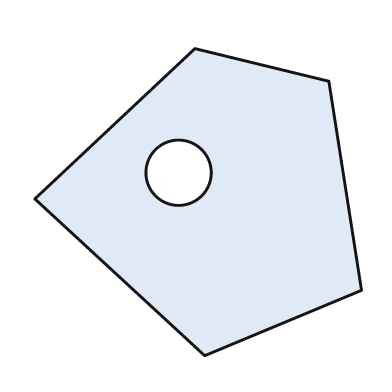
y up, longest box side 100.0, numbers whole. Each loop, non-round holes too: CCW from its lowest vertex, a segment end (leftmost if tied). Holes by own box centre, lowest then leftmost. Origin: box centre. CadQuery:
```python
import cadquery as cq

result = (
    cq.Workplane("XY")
    .moveTo(2.0, -47.0)
    .lineTo(50.0, -27.0)
    .lineTo(40.0, 37.0)
    .lineTo(-1.0, 47.0)
    .lineTo(-50.0, 1.0)
    .close()
    .moveTo(-6.0, 9.0)
    .circle(10.0)
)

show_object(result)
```